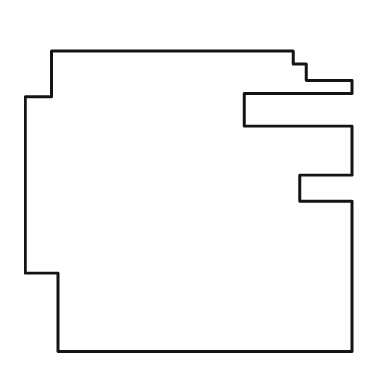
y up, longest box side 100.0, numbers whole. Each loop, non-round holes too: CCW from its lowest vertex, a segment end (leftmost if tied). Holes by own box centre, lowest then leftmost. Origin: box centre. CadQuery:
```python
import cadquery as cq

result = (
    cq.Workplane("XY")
    .moveTo(-40.0, -46.0)
    .lineTo(50.0, -46.0)
    .lineTo(50.0, 0.0)
    .lineTo(34.0, 0.0)
    .lineTo(34.0, 8.0)
    .lineTo(50.0, 8.0)
    .lineTo(50.0, 23.0)
    .lineTo(17.0, 23.0)
    .lineTo(17.0, 33.0)
    .lineTo(50.0, 33.0)
    .lineTo(50.0, 37.0)
    .lineTo(36.0, 37.0)
    .lineTo(36.0, 42.0)
    .lineTo(32.0, 42.0)
    .lineTo(32.0, 46.0)
    .lineTo(-42.0, 46.0)
    .lineTo(-42.0, 32.0)
    .lineTo(-50.0, 32.0)
    .lineTo(-50.0, -22.0)
    .lineTo(-40.0, -22.0)
    .close()
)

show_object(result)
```